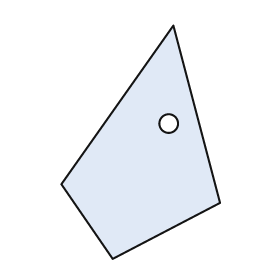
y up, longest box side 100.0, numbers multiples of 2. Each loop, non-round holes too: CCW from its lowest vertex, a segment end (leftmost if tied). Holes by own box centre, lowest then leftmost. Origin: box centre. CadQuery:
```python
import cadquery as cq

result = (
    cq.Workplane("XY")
    .moveTo(-12.0, -50.0)
    .lineTo(34.0, -26.0)
    .lineTo(14.0, 50.0)
    .lineTo(-34.0, -18.0)
    .close()
    .moveTo(12.0, 8.0)
    .circle(4.0)
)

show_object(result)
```